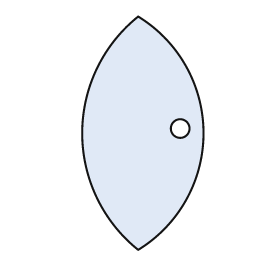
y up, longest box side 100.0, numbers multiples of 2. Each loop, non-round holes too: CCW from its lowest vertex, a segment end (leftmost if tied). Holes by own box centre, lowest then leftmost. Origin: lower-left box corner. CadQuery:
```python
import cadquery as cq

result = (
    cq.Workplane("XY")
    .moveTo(24.0, 0.0)
    .threePointArc((52.0, 50.0), (24.0, 100.0))
    .threePointArc((0.0, 50.0), (24.0, 0.0))
    .close()
    .moveTo(42.0, 52.0)
    .circle(4.0)
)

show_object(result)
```